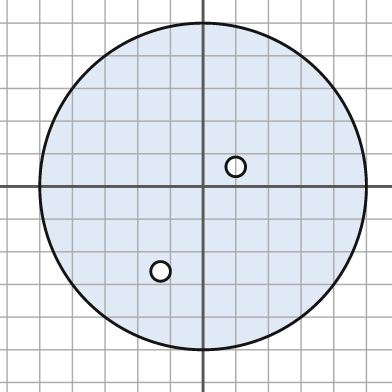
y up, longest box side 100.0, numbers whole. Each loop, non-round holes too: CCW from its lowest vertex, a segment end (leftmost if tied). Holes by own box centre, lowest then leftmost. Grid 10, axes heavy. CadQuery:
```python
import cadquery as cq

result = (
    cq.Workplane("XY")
    .moveTo(0.0, 0.0)
    .circle(50.0)
    .moveTo(-13.0, -26.0)
    .circle(3.0)
    .moveTo(10.0, 6.0)
    .circle(3.0)
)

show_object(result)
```